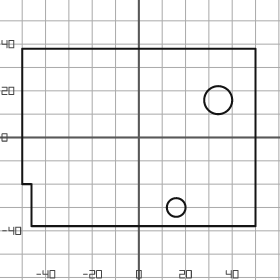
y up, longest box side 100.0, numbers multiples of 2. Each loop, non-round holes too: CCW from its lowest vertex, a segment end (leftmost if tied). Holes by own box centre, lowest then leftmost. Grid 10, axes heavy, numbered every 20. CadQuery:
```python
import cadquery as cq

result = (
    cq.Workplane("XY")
    .moveTo(-46.0, -38.0)
    .lineTo(50.0, -38.0)
    .lineTo(50.0, 38.0)
    .lineTo(-50.0, 38.0)
    .lineTo(-50.0, -20.0)
    .lineTo(-46.0, -20.0)
    .close()
    .moveTo(16.0, -30.0)
    .circle(4.0)
    .moveTo(34.0, 16.0)
    .circle(6.0)
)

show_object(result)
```